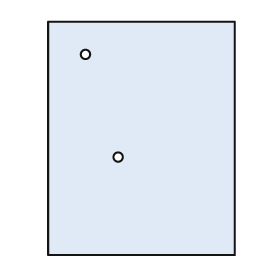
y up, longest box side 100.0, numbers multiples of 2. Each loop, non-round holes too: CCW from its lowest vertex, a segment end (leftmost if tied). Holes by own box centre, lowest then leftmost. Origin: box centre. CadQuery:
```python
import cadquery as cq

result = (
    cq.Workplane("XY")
    .moveTo(-40.0, -50.0)
    .lineTo(40.0, -50.0)
    .lineTo(40.0, 50.0)
    .lineTo(-40.0, 50.0)
    .close()
    .moveTo(-10.0, -8.0)
    .circle(2.0)
    .moveTo(-24.0, 36.0)
    .circle(2.0)
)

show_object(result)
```